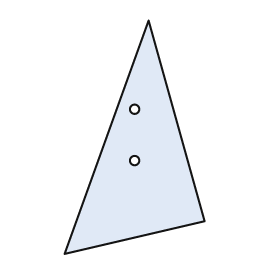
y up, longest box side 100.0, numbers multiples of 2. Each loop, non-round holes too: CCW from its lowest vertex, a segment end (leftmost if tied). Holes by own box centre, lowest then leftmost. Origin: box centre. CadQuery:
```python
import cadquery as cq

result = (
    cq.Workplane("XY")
    .moveTo(-30.0, -50.0)
    .lineTo(30.0, -36.0)
    .lineTo(6.0, 50.0)
    .close()
    .moveTo(0.0, -10.0)
    .circle(2.0)
    .moveTo(0.0, 12.0)
    .circle(2.0)
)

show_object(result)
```